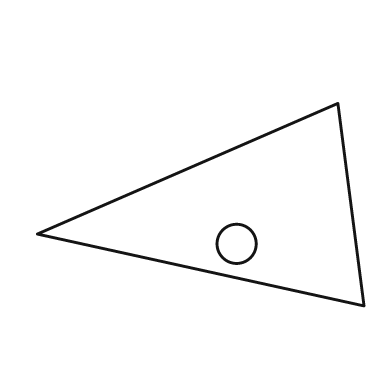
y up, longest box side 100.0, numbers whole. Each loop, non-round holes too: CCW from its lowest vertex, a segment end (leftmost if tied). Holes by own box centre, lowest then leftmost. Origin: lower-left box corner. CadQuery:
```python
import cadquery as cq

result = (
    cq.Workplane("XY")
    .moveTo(100.0, 0.0)
    .lineTo(92.0, 62.0)
    .lineTo(0.0, 22.0)
    .close()
    .moveTo(61.0, 19.0)
    .circle(6.0)
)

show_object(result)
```